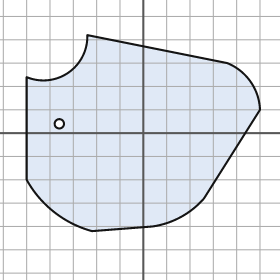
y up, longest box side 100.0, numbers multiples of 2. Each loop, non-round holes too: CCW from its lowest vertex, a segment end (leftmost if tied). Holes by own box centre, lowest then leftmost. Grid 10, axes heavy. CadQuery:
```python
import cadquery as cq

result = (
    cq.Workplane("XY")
    .moveTo(-22.0, -42.0)
    .lineTo(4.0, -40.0)
    .threePointArc((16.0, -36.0), (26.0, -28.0))
    .lineTo(50.0, 10.0)
    .threePointArc((46.0, 22.0), (36.0, 30.0))
    .lineTo(-24.0, 42.0)
    .threePointArc((-32.0, 26.0), (-50.0, 24.0))
    .lineTo(-50.0, -20.0)
    .threePointArc((-38.0, -34.0), (-22.0, -42.0))
    .close()
    .moveTo(-36.0, 4.0)
    .circle(2.0)
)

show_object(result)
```